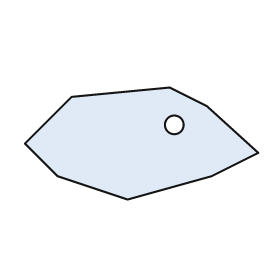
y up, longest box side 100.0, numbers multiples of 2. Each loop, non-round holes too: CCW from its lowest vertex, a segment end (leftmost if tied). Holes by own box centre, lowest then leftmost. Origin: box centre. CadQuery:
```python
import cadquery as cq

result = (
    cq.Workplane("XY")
    .moveTo(-6.0, -24.0)
    .lineTo(30.0, -14.0)
    .lineTo(50.0, -4.0)
    .lineTo(28.0, 16.0)
    .lineTo(12.0, 24.0)
    .lineTo(-30.0, 20.0)
    .lineTo(-50.0, 0.0)
    .lineTo(-36.0, -14.0)
    .close()
    .moveTo(14.0, 8.0)
    .circle(4.0)
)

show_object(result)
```